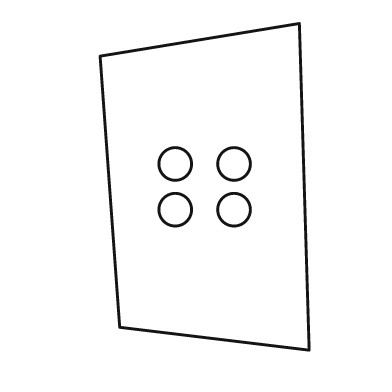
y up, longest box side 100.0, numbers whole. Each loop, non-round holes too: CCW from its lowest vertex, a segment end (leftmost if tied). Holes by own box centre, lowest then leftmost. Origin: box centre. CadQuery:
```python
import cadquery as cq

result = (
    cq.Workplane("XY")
    .moveTo(32.0, -50.0)
    .lineTo(29.0, 50.0)
    .lineTo(-32.0, 40.0)
    .lineTo(-26.0, -43.0)
    .close()
    .moveTo(-9.0, -7.0)
    .circle(5.0)
    .moveTo(9.0, -7.0)
    .circle(5.0)
    .moveTo(-9.0, 7.0)
    .circle(5.0)
    .moveTo(9.0, 7.0)
    .circle(5.0)
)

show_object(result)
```